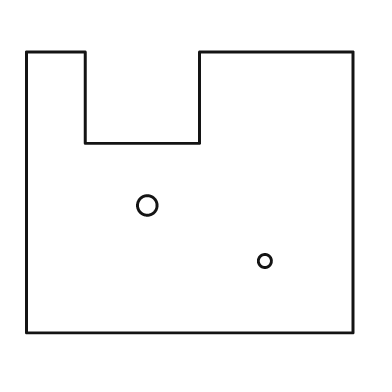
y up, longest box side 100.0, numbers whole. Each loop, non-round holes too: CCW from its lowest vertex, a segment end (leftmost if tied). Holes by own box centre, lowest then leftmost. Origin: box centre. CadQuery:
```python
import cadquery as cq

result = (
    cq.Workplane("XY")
    .moveTo(-50.0, -43.0)
    .lineTo(50.0, -43.0)
    .lineTo(50.0, 43.0)
    .lineTo(3.0, 43.0)
    .lineTo(3.0, 15.0)
    .lineTo(-32.0, 15.0)
    .lineTo(-32.0, 43.0)
    .lineTo(-50.0, 43.0)
    .close()
    .moveTo(23.0, -21.0)
    .circle(2.0)
    .moveTo(-13.0, -4.0)
    .circle(3.0)
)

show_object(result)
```